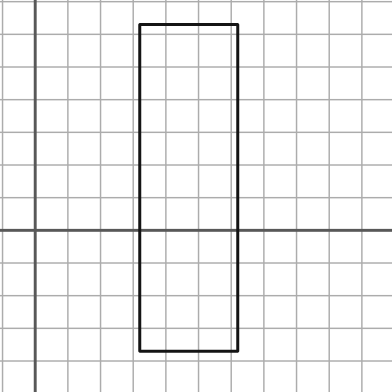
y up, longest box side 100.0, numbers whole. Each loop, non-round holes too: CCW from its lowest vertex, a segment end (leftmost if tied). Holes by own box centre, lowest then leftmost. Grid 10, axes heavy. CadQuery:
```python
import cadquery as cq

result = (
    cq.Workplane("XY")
    .moveTo(32.0, -37.0)
    .lineTo(62.0, -37.0)
    .lineTo(62.0, 63.0)
    .lineTo(32.0, 63.0)
    .close()
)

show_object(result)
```